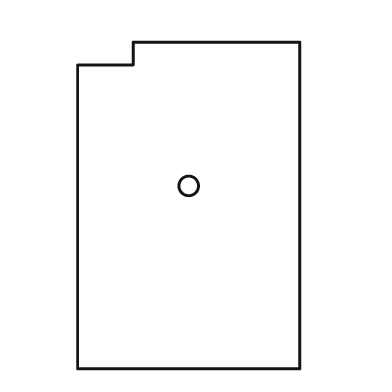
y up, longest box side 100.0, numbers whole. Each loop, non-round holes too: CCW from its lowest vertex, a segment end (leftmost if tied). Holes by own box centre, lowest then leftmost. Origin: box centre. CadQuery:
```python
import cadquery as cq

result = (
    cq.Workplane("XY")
    .moveTo(-34.0, -50.0)
    .lineTo(34.0, -50.0)
    .lineTo(34.0, 50.0)
    .lineTo(-17.0, 50.0)
    .lineTo(-17.0, 43.0)
    .lineTo(-34.0, 43.0)
    .close()
    .moveTo(0.0, 6.0)
    .circle(3.0)
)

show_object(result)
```